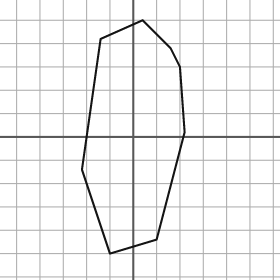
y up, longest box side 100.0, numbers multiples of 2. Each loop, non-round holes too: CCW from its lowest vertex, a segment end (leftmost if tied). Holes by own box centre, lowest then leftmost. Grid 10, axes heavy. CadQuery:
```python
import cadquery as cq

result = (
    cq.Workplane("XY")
    .moveTo(-10.0, -50.0)
    .lineTo(10.0, -44.0)
    .lineTo(22.0, 2.0)
    .lineTo(20.0, 30.0)
    .lineTo(16.0, 38.0)
    .lineTo(4.0, 50.0)
    .lineTo(-14.0, 42.0)
    .lineTo(-22.0, -14.0)
    .close()
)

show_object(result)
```